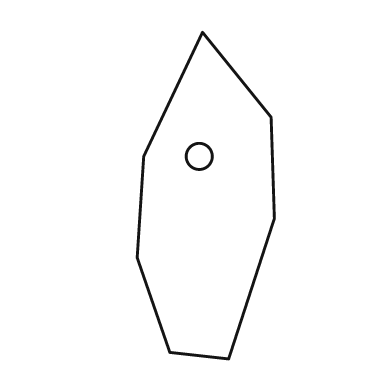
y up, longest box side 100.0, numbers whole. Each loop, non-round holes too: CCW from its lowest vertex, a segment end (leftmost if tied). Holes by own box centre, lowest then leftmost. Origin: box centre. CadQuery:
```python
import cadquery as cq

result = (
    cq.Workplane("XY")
    .moveTo(7.0, -50.0)
    .lineTo(21.0, -7.0)
    .lineTo(20.0, 24.0)
    .lineTo(-1.0, 50.0)
    .lineTo(-19.0, 12.0)
    .lineTo(-21.0, -19.0)
    .lineTo(-11.0, -48.0)
    .close()
    .moveTo(-2.0, 12.0)
    .circle(4.0)
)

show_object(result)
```